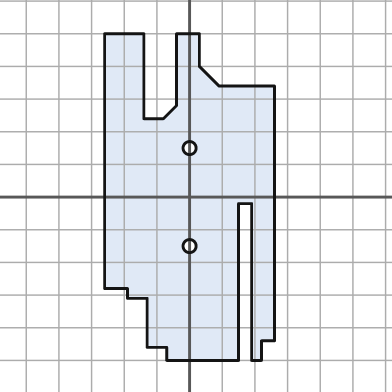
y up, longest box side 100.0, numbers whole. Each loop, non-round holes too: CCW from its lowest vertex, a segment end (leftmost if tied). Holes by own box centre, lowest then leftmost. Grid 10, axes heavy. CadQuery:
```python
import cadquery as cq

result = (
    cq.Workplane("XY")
    .moveTo(-7.0, -50.0)
    .lineTo(15.0, -50.0)
    .lineTo(15.0, -2.0)
    .lineTo(19.0, -2.0)
    .lineTo(19.0, -50.0)
    .lineTo(22.0, -50.0)
    .lineTo(22.0, -44.0)
    .lineTo(26.0, -44.0)
    .lineTo(26.0, 34.0)
    .lineTo(9.0, 34.0)
    .lineTo(3.0, 40.0)
    .lineTo(3.0, 50.0)
    .lineTo(-4.0, 50.0)
    .lineTo(-4.0, 28.0)
    .lineTo(-8.0, 24.0)
    .lineTo(-14.0, 24.0)
    .lineTo(-14.0, 50.0)
    .lineTo(-26.0, 50.0)
    .lineTo(-26.0, -28.0)
    .lineTo(-19.0, -28.0)
    .lineTo(-19.0, -31.0)
    .lineTo(-13.0, -31.0)
    .lineTo(-13.0, -46.0)
    .lineTo(-7.0, -46.0)
    .close()
    .moveTo(0.0, -15.0)
    .circle(2.0)
    .moveTo(0.0, 15.0)
    .circle(2.0)
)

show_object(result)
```